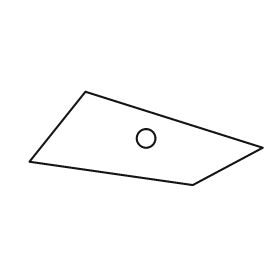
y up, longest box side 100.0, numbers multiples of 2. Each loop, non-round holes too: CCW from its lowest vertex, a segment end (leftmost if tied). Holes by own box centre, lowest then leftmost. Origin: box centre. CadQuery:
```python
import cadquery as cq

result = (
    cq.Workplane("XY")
    .moveTo(20.0, -20.0)
    .lineTo(50.0, -4.0)
    .lineTo(-26.0, 20.0)
    .lineTo(-50.0, -10.0)
    .close()
    .moveTo(0.0, 0.0)
    .circle(4.0)
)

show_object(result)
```